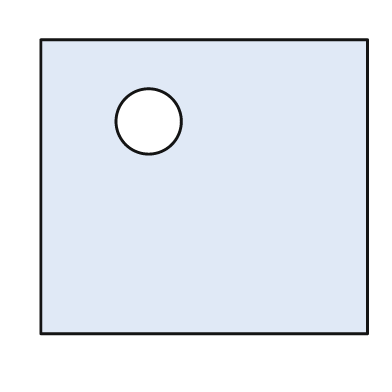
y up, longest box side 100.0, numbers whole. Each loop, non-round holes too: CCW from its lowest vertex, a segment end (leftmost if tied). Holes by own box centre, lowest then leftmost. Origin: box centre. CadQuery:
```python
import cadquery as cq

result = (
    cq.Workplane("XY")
    .moveTo(-50.0, -45.0)
    .lineTo(50.0, -45.0)
    .lineTo(50.0, 45.0)
    .lineTo(-50.0, 45.0)
    .close()
    .moveTo(-17.0, 20.0)
    .circle(10.0)
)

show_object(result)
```